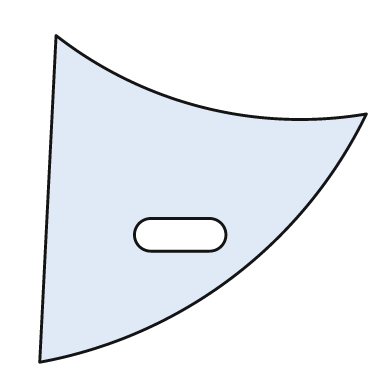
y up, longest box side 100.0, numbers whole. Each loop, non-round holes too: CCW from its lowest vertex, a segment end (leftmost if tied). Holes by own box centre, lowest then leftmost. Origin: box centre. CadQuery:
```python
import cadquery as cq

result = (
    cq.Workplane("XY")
    .moveTo(-50.0, -50.0)
    .threePointArc((9.0, -24.0), (50.0, 26.0))
    .threePointArc((0.0, 28.0), (-45.0, 50.0))
    .close()
    .moveTo(-16.0, -16.0)
    .lineTo(2.0, -16.0)
    .threePointArc((7.0, -11.0), (2.0, -6.0))
    .lineTo(-16.0, -6.0)
    .threePointArc((-21.0, -11.0), (-16.0, -16.0))
    .close()
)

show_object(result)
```